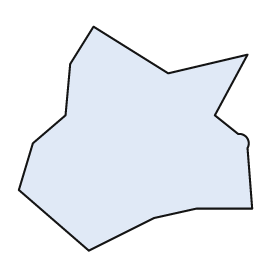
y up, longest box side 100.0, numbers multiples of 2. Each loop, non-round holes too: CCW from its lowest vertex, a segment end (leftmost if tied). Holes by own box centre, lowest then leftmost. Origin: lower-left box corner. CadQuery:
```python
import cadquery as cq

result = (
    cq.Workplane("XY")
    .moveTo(30.0, 0.0)
    .lineTo(58.0, 14.0)
    .lineTo(76.0, 18.0)
    .lineTo(100.0, 18.0)
    .lineTo(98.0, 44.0)
    .threePointArc((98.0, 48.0), (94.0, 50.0))
    .lineTo(84.0, 58.0)
    .lineTo(98.0, 84.0)
    .lineTo(64.0, 76.0)
    .lineTo(32.0, 96.0)
    .lineTo(22.0, 80.0)
    .lineTo(20.0, 58.0)
    .lineTo(6.0, 46.0)
    .lineTo(0.0, 26.0)
    .close()
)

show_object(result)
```